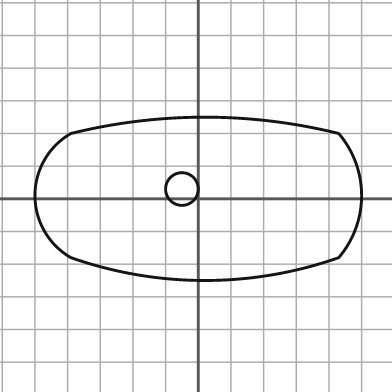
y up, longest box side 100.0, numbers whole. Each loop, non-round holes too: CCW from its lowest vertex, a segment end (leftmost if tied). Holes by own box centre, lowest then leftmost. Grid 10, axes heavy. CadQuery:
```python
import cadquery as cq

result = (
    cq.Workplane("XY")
    .moveTo(-39.0, -18.0)
    .threePointArc((2.0, -25.0), (43.0, -18.0))
    .threePointArc((50.0, 1.0), (43.0, 20.0))
    .threePointArc((2.0, 25.0), (-39.0, 20.0))
    .threePointArc((-50.0, 1.0), (-39.0, -18.0))
    .close()
    .moveTo(-5.0, 3.0)
    .circle(5.0)
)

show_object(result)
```